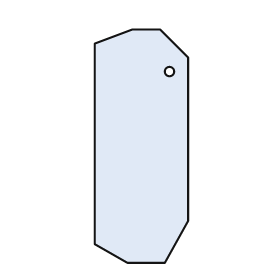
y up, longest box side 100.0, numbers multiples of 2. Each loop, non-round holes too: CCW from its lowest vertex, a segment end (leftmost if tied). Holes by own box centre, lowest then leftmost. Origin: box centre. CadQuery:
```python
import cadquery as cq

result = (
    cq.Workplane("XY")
    .moveTo(-6.0, -50.0)
    .lineTo(10.0, -50.0)
    .lineTo(20.0, -32.0)
    .lineTo(20.0, 38.0)
    .lineTo(8.0, 50.0)
    .lineTo(-4.0, 50.0)
    .lineTo(-20.0, 44.0)
    .lineTo(-20.0, -42.0)
    .close()
    .moveTo(12.0, 32.0)
    .circle(2.0)
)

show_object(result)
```